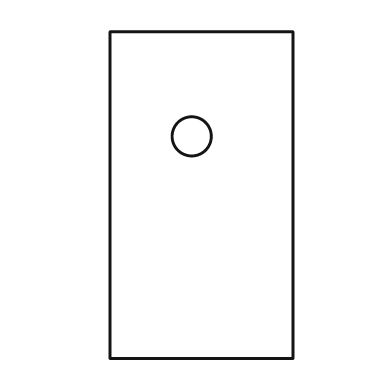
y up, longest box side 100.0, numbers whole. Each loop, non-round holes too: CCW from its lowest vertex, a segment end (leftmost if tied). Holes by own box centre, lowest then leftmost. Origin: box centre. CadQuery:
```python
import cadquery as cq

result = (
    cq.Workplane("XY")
    .moveTo(-28.0, -50.0)
    .lineTo(28.0, -50.0)
    .lineTo(28.0, 50.0)
    .lineTo(-28.0, 50.0)
    .close()
    .moveTo(-3.0, 18.0)
    .circle(6.0)
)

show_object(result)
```